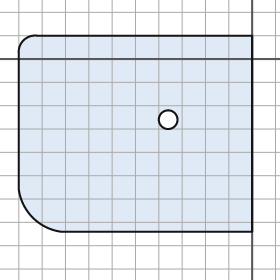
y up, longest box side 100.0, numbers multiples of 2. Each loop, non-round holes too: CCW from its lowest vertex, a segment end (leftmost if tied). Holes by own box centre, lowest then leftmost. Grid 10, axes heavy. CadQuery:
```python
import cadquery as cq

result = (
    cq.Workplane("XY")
    .moveTo(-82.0, -74.0)
    .lineTo(0.0, -74.0)
    .lineTo(0.0, 10.0)
    .lineTo(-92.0, 10.0)
    .threePointArc((-98.0, 8.0), (-100.0, 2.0))
    .lineTo(-100.0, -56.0)
    .threePointArc((-94.0, -68.0), (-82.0, -74.0))
    .close()
    .moveTo(-36.0, -26.0)
    .circle(4.0)
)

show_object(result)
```